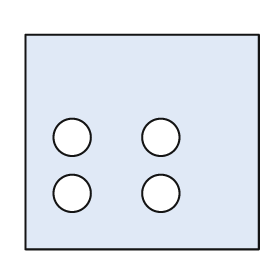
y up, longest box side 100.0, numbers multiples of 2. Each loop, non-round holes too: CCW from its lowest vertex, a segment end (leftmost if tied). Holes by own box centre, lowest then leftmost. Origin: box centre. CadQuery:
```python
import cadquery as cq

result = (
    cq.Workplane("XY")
    .moveTo(-50.0, -46.0)
    .lineTo(50.0, -46.0)
    .lineTo(50.0, 46.0)
    .lineTo(-50.0, 46.0)
    .close()
    .moveTo(-30.0, -22.0)
    .circle(8.0)
    .moveTo(8.0, -22.0)
    .circle(8.0)
    .moveTo(-30.0, 2.0)
    .circle(8.0)
    .moveTo(8.0, 2.0)
    .circle(8.0)
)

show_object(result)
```